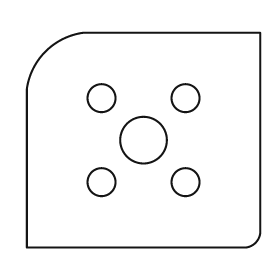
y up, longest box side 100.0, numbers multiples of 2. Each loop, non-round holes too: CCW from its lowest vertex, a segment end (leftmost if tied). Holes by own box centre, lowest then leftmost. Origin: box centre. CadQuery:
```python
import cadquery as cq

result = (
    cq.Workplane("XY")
    .moveTo(-50.0, -46.0)
    .lineTo(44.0, -46.0)
    .threePointArc((48.0, -44.0), (50.0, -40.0))
    .lineTo(50.0, 46.0)
    .lineTo(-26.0, 46.0)
    .threePointArc((-42.0, 38.0), (-50.0, 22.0))
    .close()
    .moveTo(-18.0, -18.0)
    .circle(6.0)
    .moveTo(18.0, -18.0)
    .circle(6.0)
    .moveTo(0.0, 0.0)
    .circle(10.0)
    .moveTo(-18.0, 18.0)
    .circle(6.0)
    .moveTo(18.0, 18.0)
    .circle(6.0)
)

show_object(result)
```